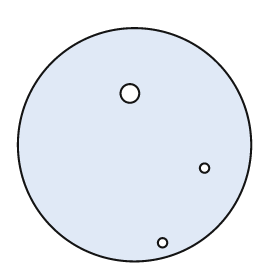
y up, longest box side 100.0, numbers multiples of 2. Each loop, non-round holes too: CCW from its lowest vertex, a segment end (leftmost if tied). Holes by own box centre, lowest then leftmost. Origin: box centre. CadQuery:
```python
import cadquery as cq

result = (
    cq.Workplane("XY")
    .moveTo(0.0, 0.0)
    .circle(50.0)
    .moveTo(12.0, -42.0)
    .circle(2.0)
    .moveTo(30.0, -10.0)
    .circle(2.0)
    .moveTo(-2.0, 22.0)
    .circle(4.0)
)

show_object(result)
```